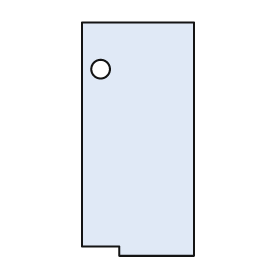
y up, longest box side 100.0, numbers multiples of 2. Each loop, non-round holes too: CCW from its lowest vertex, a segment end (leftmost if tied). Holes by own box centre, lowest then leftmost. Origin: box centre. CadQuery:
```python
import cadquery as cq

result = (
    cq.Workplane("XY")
    .moveTo(-8.0, -50.0)
    .lineTo(24.0, -50.0)
    .lineTo(24.0, 50.0)
    .lineTo(-24.0, 50.0)
    .lineTo(-24.0, -46.0)
    .lineTo(-8.0, -46.0)
    .close()
    .moveTo(-16.0, 30.0)
    .circle(4.0)
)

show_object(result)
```